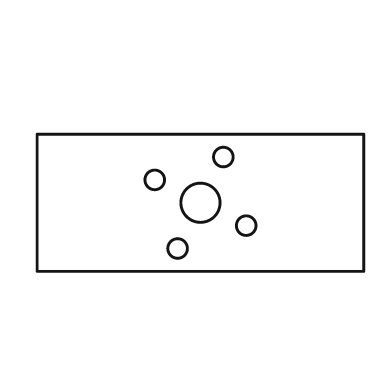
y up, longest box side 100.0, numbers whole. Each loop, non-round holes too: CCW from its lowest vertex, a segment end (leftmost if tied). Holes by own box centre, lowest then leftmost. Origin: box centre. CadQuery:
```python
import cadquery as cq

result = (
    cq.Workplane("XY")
    .moveTo(-50.0, -21.0)
    .lineTo(50.0, -21.0)
    .lineTo(50.0, 21.0)
    .lineTo(-50.0, 21.0)
    .close()
    .moveTo(-7.0, -14.0)
    .circle(3.0)
    .moveTo(14.0, -7.0)
    .circle(3.0)
    .moveTo(0.0, 0.0)
    .circle(6.0)
    .moveTo(-14.0, 7.0)
    .circle(3.0)
    .moveTo(7.0, 14.0)
    .circle(3.0)
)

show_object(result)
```